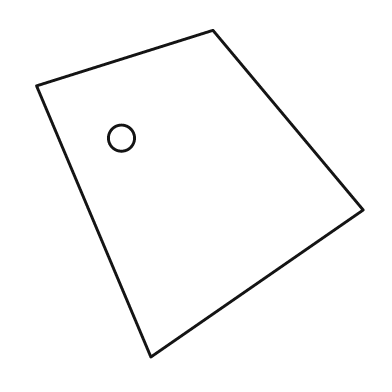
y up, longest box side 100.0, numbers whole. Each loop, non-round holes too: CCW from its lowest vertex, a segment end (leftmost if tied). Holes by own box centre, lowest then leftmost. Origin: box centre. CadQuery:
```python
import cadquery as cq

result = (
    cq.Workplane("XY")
    .moveTo(-15.0, -50.0)
    .lineTo(50.0, -5.0)
    .lineTo(4.0, 50.0)
    .lineTo(-50.0, 33.0)
    .close()
    .moveTo(-24.0, 17.0)
    .circle(4.0)
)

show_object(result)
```